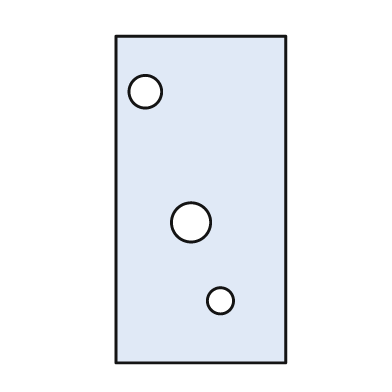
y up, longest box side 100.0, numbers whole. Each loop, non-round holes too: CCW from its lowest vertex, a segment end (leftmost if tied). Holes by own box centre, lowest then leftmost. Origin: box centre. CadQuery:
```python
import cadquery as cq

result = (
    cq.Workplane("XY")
    .moveTo(-26.0, -50.0)
    .lineTo(26.0, -50.0)
    .lineTo(26.0, 50.0)
    .lineTo(-26.0, 50.0)
    .close()
    .moveTo(6.0, -31.0)
    .circle(4.0)
    .moveTo(-3.0, -7.0)
    .circle(6.0)
    .moveTo(-17.0, 33.0)
    .circle(5.0)
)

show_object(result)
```